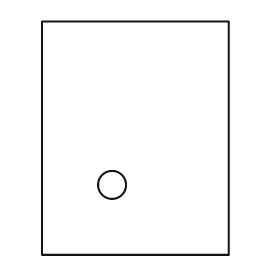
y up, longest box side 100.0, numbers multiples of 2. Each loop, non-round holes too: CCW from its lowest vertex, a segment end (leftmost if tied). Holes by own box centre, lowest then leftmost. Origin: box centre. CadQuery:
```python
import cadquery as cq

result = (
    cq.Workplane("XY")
    .moveTo(-40.0, -50.0)
    .lineTo(40.0, -50.0)
    .lineTo(40.0, 50.0)
    .lineTo(-40.0, 50.0)
    .close()
    .moveTo(-10.0, -20.0)
    .circle(6.0)
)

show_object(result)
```